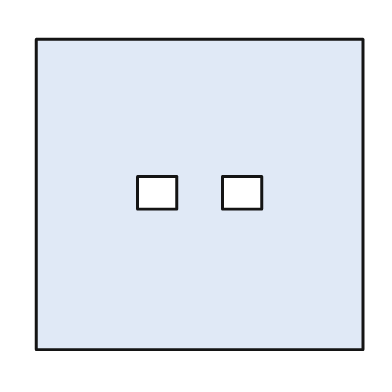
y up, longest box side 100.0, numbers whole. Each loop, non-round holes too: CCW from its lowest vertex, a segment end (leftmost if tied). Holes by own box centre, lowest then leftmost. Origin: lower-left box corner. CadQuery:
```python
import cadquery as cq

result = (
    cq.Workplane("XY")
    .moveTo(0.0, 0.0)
    .lineTo(100.0, 0.0)
    .lineTo(100.0, 95.0)
    .lineTo(0.0, 95.0)
    .close()
    .moveTo(31.0, 43.0)
    .lineTo(43.0, 43.0)
    .lineTo(43.0, 53.0)
    .lineTo(31.0, 53.0)
    .close()
    .moveTo(57.0, 43.0)
    .lineTo(69.0, 43.0)
    .lineTo(69.0, 53.0)
    .lineTo(57.0, 53.0)
    .close()
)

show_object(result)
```